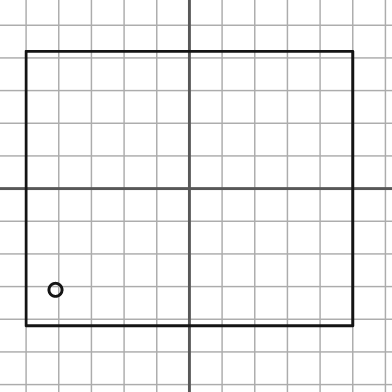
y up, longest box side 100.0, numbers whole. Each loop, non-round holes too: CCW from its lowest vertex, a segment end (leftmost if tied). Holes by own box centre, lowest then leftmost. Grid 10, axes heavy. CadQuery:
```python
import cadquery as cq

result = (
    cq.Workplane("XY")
    .moveTo(-50.0, -42.0)
    .lineTo(50.0, -42.0)
    .lineTo(50.0, 42.0)
    .lineTo(-50.0, 42.0)
    .close()
    .moveTo(-41.0, -31.0)
    .circle(2.0)
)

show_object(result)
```